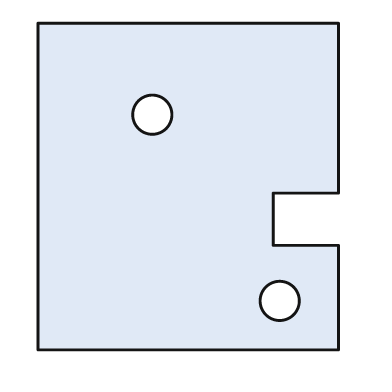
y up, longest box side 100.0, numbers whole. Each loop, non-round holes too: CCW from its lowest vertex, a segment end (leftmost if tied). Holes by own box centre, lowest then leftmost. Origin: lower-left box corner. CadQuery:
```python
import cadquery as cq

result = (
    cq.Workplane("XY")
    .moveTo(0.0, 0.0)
    .lineTo(92.0, 0.0)
    .lineTo(92.0, 32.0)
    .lineTo(72.0, 32.0)
    .lineTo(72.0, 48.0)
    .lineTo(92.0, 48.0)
    .lineTo(92.0, 100.0)
    .lineTo(0.0, 100.0)
    .close()
    .moveTo(74.0, 15.0)
    .circle(6.0)
    .moveTo(35.0, 72.0)
    .circle(6.0)
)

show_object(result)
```